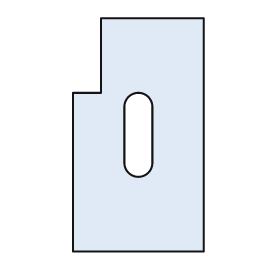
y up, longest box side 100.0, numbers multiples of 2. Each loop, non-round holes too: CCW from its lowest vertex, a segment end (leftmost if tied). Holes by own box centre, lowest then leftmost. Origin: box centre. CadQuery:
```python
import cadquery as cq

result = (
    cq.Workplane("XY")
    .moveTo(-28.0, -50.0)
    .lineTo(28.0, -50.0)
    .lineTo(28.0, 50.0)
    .lineTo(-16.0, 50.0)
    .lineTo(-16.0, 18.0)
    .lineTo(-28.0, 18.0)
    .close()
    .moveTo(-6.0, -12.0)
    .threePointArc((0.0, -18.0), (6.0, -12.0))
    .lineTo(6.0, 12.0)
    .threePointArc((0.0, 18.0), (-6.0, 12.0))
    .close()
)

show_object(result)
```